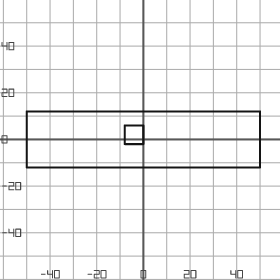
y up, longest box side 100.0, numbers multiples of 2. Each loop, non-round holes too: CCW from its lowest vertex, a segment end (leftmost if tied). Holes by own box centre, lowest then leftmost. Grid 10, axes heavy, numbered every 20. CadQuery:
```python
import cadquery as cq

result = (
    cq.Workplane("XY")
    .moveTo(-50.0, -12.0)
    .lineTo(50.0, -12.0)
    .lineTo(50.0, 12.0)
    .lineTo(-50.0, 12.0)
    .close()
    .moveTo(-8.0, -2.0)
    .lineTo(0.0, -2.0)
    .lineTo(0.0, 6.0)
    .lineTo(-8.0, 6.0)
    .close()
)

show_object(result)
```